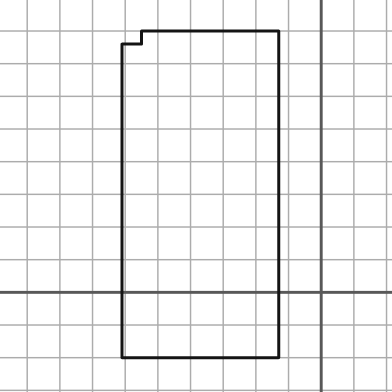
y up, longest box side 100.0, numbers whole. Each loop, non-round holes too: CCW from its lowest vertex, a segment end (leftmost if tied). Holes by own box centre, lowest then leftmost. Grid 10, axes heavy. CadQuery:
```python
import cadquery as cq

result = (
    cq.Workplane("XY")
    .moveTo(-61.0, -20.0)
    .lineTo(-13.0, -20.0)
    .lineTo(-13.0, 80.0)
    .lineTo(-55.0, 80.0)
    .lineTo(-55.0, 76.0)
    .lineTo(-61.0, 76.0)
    .close()
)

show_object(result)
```